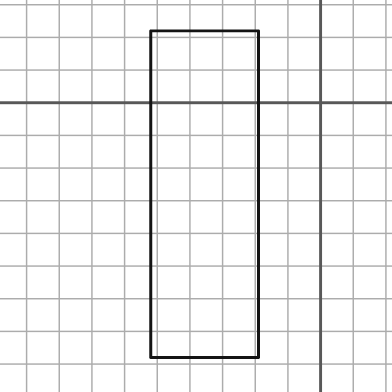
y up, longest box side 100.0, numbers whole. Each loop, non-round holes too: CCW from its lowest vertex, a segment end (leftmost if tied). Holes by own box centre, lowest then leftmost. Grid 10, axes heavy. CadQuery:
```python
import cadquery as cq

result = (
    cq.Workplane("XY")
    .moveTo(-52.0, -78.0)
    .lineTo(-19.0, -78.0)
    .lineTo(-19.0, 22.0)
    .lineTo(-52.0, 22.0)
    .close()
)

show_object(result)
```